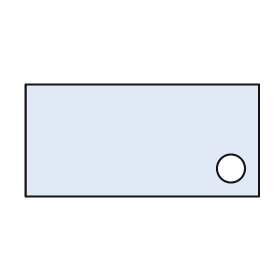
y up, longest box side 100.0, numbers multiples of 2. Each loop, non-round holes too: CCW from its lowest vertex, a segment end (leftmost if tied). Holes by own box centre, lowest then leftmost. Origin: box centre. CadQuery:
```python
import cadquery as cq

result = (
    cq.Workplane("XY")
    .moveTo(-50.0, -24.0)
    .lineTo(50.0, -24.0)
    .lineTo(50.0, 24.0)
    .lineTo(-50.0, 24.0)
    .close()
    .moveTo(38.0, -12.0)
    .circle(6.0)
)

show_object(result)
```